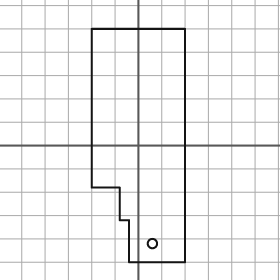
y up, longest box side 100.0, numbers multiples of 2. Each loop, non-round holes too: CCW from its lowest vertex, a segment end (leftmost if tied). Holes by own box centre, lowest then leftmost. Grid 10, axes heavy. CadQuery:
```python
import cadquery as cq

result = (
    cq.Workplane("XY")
    .moveTo(-4.0, -50.0)
    .lineTo(20.0, -50.0)
    .lineTo(20.0, 50.0)
    .lineTo(-20.0, 50.0)
    .lineTo(-20.0, -18.0)
    .lineTo(-8.0, -18.0)
    .lineTo(-8.0, -32.0)
    .lineTo(-4.0, -32.0)
    .close()
    .moveTo(6.0, -42.0)
    .circle(2.0)
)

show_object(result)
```